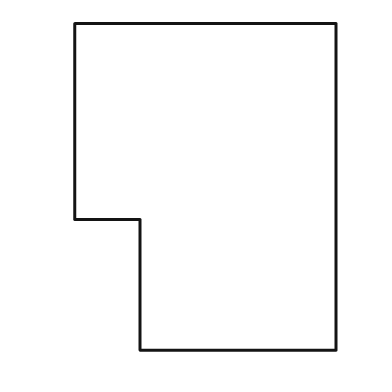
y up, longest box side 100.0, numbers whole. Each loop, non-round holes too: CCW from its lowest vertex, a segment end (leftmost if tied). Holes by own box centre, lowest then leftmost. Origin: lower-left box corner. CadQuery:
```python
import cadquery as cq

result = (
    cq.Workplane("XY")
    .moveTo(20.0, 0.0)
    .lineTo(80.0, 0.0)
    .lineTo(80.0, 100.0)
    .lineTo(0.0, 100.0)
    .lineTo(0.0, 40.0)
    .lineTo(20.0, 40.0)
    .close()
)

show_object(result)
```